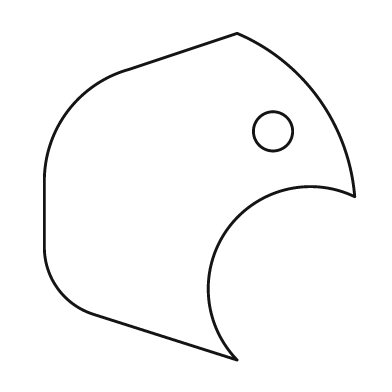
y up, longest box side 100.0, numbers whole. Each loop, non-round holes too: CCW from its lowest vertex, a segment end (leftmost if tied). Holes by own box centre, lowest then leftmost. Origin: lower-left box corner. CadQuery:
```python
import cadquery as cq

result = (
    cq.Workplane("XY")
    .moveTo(59.0, 0.0)
    .threePointArc((56.0, 40.0), (95.0, 50.0))
    .threePointArc((84.0, 80.0), (59.0, 100.0))
    .lineTo(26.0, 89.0)
    .threePointArc((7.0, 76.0), (0.0, 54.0))
    .lineTo(0.0, 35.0)
    .threePointArc((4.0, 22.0), (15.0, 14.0))
    .close()
    .moveTo(70.0, 70.0)
    .circle(6.0)
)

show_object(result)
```